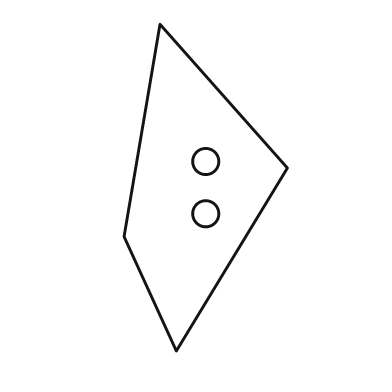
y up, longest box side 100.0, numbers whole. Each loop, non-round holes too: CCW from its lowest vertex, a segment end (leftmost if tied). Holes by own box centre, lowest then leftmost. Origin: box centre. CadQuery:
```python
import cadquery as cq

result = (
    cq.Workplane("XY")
    .moveTo(-9.0, -50.0)
    .lineTo(25.0, 6.0)
    .lineTo(-14.0, 50.0)
    .lineTo(-25.0, -15.0)
    .close()
    .moveTo(0.0, -8.0)
    .circle(4.0)
    .moveTo(0.0, 8.0)
    .circle(4.0)
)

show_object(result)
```